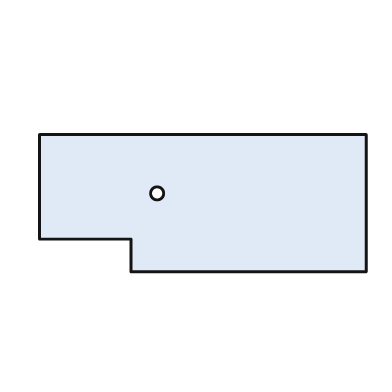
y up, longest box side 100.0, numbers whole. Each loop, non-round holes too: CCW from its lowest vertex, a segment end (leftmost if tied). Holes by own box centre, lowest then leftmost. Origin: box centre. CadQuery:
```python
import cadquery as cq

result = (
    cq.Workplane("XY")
    .moveTo(-22.0, -21.0)
    .lineTo(50.0, -21.0)
    .lineTo(50.0, 21.0)
    .lineTo(-50.0, 21.0)
    .lineTo(-50.0, -11.0)
    .lineTo(-22.0, -11.0)
    .close()
    .moveTo(-14.0, 3.0)
    .circle(2.0)
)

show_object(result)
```